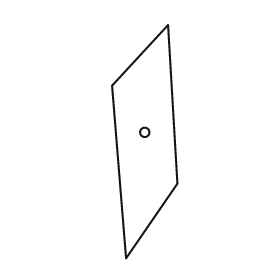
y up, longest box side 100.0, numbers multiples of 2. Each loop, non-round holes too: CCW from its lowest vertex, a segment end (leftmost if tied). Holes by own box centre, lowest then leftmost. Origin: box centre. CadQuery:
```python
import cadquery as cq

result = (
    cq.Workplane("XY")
    .moveTo(-8.0, -50.0)
    .lineTo(14.0, -18.0)
    .lineTo(10.0, 50.0)
    .lineTo(-14.0, 24.0)
    .close()
    .moveTo(0.0, 4.0)
    .circle(2.0)
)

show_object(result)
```